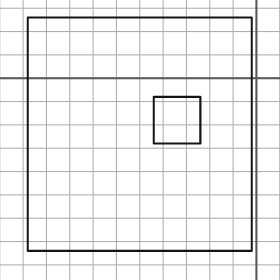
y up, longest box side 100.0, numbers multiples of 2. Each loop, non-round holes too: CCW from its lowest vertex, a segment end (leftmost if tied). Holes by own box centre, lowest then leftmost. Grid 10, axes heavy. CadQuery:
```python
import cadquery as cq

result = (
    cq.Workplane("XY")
    .moveTo(-98.0, -74.0)
    .lineTo(-2.0, -74.0)
    .lineTo(-2.0, 26.0)
    .lineTo(-98.0, 26.0)
    .close()
    .moveTo(-44.0, -28.0)
    .lineTo(-24.0, -28.0)
    .lineTo(-24.0, -8.0)
    .lineTo(-44.0, -8.0)
    .close()
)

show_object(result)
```